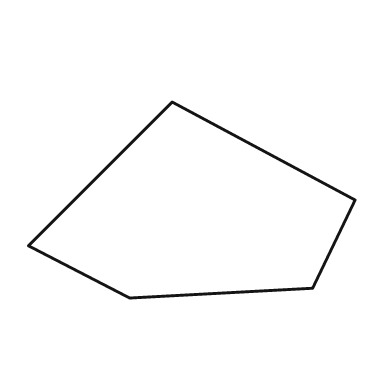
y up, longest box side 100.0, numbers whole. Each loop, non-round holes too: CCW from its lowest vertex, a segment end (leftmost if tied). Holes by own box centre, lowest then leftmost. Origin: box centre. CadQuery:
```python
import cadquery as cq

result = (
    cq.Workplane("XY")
    .moveTo(-19.0, -30.0)
    .lineTo(37.0, -27.0)
    .lineTo(50.0, 0.0)
    .lineTo(-6.0, 30.0)
    .lineTo(-50.0, -14.0)
    .close()
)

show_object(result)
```